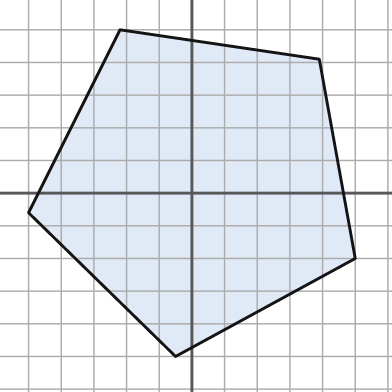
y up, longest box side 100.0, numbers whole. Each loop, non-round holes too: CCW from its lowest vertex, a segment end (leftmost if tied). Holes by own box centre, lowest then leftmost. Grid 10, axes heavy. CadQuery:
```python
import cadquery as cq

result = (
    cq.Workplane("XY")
    .moveTo(-5.0, -50.0)
    .lineTo(50.0, -20.0)
    .lineTo(39.0, 41.0)
    .lineTo(-22.0, 50.0)
    .lineTo(-50.0, -6.0)
    .close()
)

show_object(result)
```